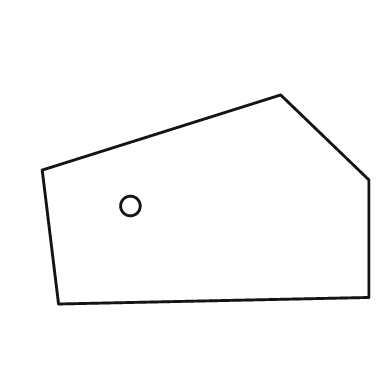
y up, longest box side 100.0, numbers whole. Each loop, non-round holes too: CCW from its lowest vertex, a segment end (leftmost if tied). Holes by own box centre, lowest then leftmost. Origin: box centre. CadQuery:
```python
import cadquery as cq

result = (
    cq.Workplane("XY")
    .moveTo(-45.0, -32.0)
    .lineTo(50.0, -30.0)
    .lineTo(50.0, 6.0)
    .lineTo(23.0, 32.0)
    .lineTo(-50.0, 9.0)
    .close()
    .moveTo(-23.0, -2.0)
    .circle(3.0)
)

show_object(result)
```